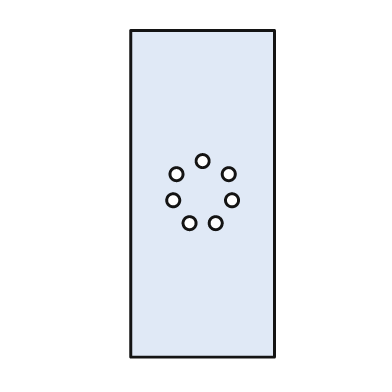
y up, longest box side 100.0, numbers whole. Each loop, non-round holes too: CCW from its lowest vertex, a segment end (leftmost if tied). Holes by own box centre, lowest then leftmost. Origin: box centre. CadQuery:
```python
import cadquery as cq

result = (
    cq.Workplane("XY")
    .moveTo(-22.0, -50.0)
    .lineTo(22.0, -50.0)
    .lineTo(22.0, 50.0)
    .lineTo(-22.0, 50.0)
    .close()
    .moveTo(-4.0, -9.0)
    .circle(2.0)
    .moveTo(4.0, -9.0)
    .circle(2.0)
    .moveTo(-9.0, -2.0)
    .circle(2.0)
    .moveTo(9.0, -2.0)
    .circle(2.0)
    .moveTo(-8.0, 6.0)
    .circle(2.0)
    .moveTo(8.0, 6.0)
    .circle(2.0)
    .moveTo(0.0, 10.0)
    .circle(2.0)
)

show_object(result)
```